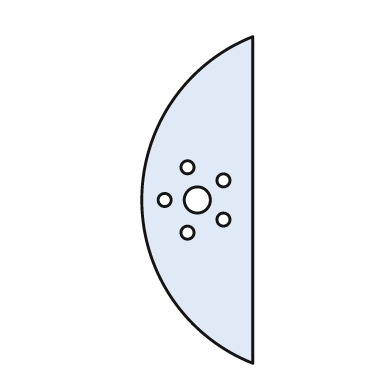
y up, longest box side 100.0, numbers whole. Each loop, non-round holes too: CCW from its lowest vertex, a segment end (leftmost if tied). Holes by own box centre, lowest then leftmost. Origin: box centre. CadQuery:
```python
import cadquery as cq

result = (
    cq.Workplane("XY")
    .moveTo(17.0, -50.0)
    .lineTo(17.0, 50.0)
    .threePointArc((-17.0, 0.0), (17.0, -50.0))
    .close()
    .moveTo(-3.0, -10.0)
    .circle(2.0)
    .moveTo(8.0, -6.0)
    .circle(2.0)
    .moveTo(-10.0, 0.0)
    .circle(2.0)
    .moveTo(0.0, 0.0)
    .circle(4.0)
    .moveTo(8.0, 6.0)
    .circle(2.0)
    .moveTo(-3.0, 10.0)
    .circle(2.0)
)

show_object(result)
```